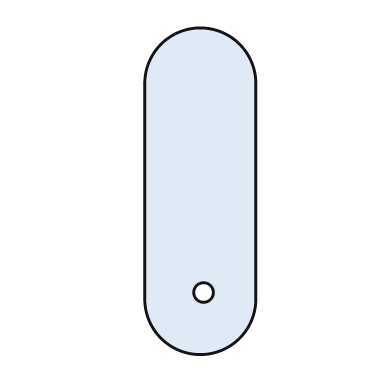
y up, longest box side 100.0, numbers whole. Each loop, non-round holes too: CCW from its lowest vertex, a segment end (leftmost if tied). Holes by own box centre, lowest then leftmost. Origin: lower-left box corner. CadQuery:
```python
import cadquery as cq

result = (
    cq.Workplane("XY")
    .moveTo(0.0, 17.0)
    .threePointArc((17.0, 0.0), (34.0, 17.0))
    .lineTo(34.0, 83.0)
    .threePointArc((17.0, 100.0), (0.0, 83.0))
    .close()
    .moveTo(18.0, 19.0)
    .circle(3.0)
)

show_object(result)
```